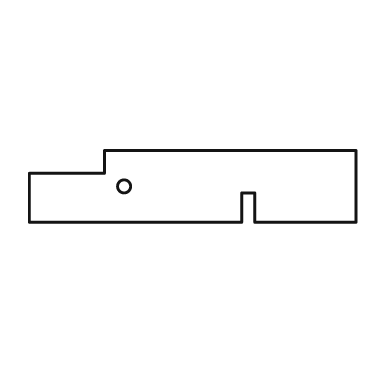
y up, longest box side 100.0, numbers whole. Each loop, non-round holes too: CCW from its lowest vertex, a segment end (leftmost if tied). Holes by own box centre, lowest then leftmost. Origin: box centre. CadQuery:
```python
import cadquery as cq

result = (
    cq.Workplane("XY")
    .moveTo(-50.0, -11.0)
    .lineTo(15.0, -11.0)
    .lineTo(15.0, -2.0)
    .lineTo(19.0, -2.0)
    .lineTo(19.0, -11.0)
    .lineTo(50.0, -11.0)
    .lineTo(50.0, 11.0)
    .lineTo(-27.0, 11.0)
    .lineTo(-27.0, 4.0)
    .lineTo(-50.0, 4.0)
    .close()
    .moveTo(-21.0, 0.0)
    .circle(2.0)
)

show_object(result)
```